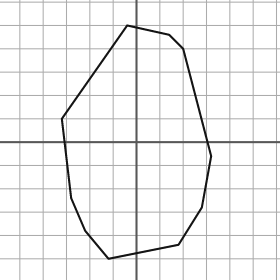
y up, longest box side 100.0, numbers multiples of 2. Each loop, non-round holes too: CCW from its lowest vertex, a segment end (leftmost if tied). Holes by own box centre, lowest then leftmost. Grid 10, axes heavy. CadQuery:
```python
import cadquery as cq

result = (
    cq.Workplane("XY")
    .moveTo(-12.0, -50.0)
    .lineTo(18.0, -44.0)
    .lineTo(28.0, -28.0)
    .lineTo(32.0, -6.0)
    .lineTo(20.0, 40.0)
    .lineTo(14.0, 46.0)
    .lineTo(-4.0, 50.0)
    .lineTo(-32.0, 10.0)
    .lineTo(-28.0, -24.0)
    .lineTo(-22.0, -38.0)
    .close()
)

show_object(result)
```